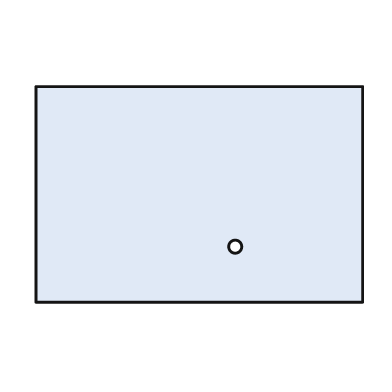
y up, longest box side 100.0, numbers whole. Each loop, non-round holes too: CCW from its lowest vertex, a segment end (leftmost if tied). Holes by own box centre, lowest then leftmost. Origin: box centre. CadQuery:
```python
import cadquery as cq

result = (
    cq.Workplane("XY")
    .moveTo(-50.0, -33.0)
    .lineTo(50.0, -33.0)
    .lineTo(50.0, 33.0)
    .lineTo(-50.0, 33.0)
    .close()
    .moveTo(11.0, -16.0)
    .circle(2.0)
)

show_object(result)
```